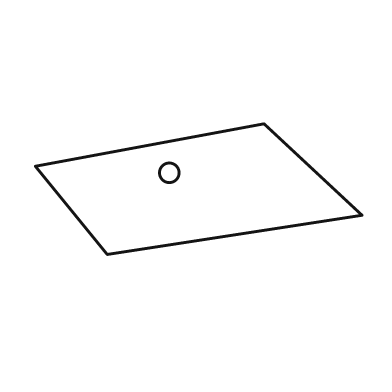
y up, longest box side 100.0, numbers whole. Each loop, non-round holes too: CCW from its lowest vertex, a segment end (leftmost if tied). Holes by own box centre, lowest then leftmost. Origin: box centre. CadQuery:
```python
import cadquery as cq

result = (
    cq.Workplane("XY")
    .moveTo(-28.0, -20.0)
    .lineTo(50.0, -8.0)
    .lineTo(20.0, 20.0)
    .lineTo(-50.0, 7.0)
    .close()
    .moveTo(-9.0, 5.0)
    .circle(3.0)
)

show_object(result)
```